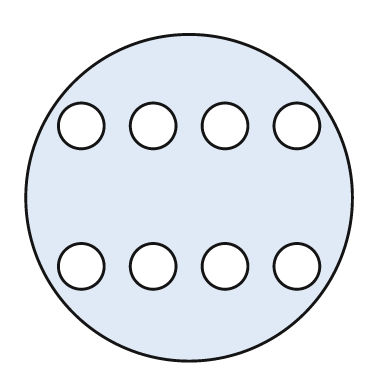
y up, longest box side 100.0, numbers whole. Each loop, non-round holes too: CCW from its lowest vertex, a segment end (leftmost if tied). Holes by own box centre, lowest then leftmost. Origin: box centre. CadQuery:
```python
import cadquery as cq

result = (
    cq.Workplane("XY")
    .moveTo(0.0, 0.0)
    .circle(50.0)
    .moveTo(-33.0, -21.0)
    .circle(7.0)
    .moveTo(-11.0, -21.0)
    .circle(7.0)
    .moveTo(11.0, -21.0)
    .circle(7.0)
    .moveTo(33.0, -21.0)
    .circle(7.0)
    .moveTo(-33.0, 22.0)
    .circle(7.0)
    .moveTo(-11.0, 22.0)
    .circle(7.0)
    .moveTo(11.0, 22.0)
    .circle(7.0)
    .moveTo(33.0, 22.0)
    .circle(7.0)
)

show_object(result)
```